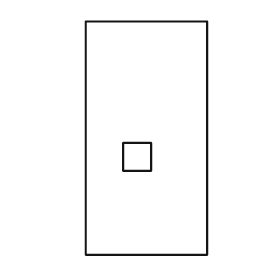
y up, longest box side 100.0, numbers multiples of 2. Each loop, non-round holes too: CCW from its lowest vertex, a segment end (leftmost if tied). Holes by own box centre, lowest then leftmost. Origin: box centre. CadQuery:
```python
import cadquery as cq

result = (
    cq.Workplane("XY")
    .moveTo(-26.0, -50.0)
    .lineTo(26.0, -50.0)
    .lineTo(26.0, 50.0)
    .lineTo(-26.0, 50.0)
    .close()
    .moveTo(-10.0, -14.0)
    .lineTo(2.0, -14.0)
    .lineTo(2.0, -2.0)
    .lineTo(-10.0, -2.0)
    .close()
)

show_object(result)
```